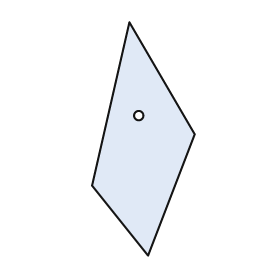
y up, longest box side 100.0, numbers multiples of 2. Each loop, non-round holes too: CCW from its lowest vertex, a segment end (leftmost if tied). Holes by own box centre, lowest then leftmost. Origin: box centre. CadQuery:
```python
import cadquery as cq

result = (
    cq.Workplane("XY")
    .moveTo(2.0, -50.0)
    .lineTo(22.0, 2.0)
    .lineTo(-6.0, 50.0)
    .lineTo(-22.0, -20.0)
    .close()
    .moveTo(-2.0, 10.0)
    .circle(2.0)
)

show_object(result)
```